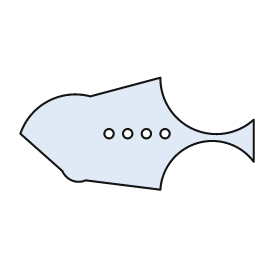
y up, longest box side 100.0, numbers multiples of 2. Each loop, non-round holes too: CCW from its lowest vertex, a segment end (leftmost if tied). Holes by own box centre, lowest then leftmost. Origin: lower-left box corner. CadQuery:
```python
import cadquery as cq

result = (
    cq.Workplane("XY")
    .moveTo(60.0, 0.0)
    .threePointArc((76.0, 20.0), (100.0, 12.0))
    .lineTo(100.0, 30.0)
    .threePointArc((74.0, 26.0), (60.0, 48.0))
    .lineTo(30.0, 40.0)
    .threePointArc((12.0, 38.0), (0.0, 24.0))
    .lineTo(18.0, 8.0)
    .threePointArc((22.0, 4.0), (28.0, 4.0))
    .close()
    .moveTo(38.0, 24.0)
    .circle(2.0)
    .moveTo(46.0, 24.0)
    .circle(2.0)
    .moveTo(54.0, 24.0)
    .circle(2.0)
    .moveTo(62.0, 24.0)
    .circle(2.0)
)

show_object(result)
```